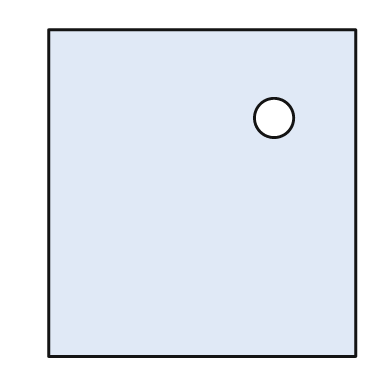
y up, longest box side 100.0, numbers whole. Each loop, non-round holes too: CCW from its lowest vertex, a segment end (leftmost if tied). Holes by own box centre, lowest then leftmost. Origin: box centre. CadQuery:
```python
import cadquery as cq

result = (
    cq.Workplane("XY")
    .moveTo(-47.0, -50.0)
    .lineTo(47.0, -50.0)
    .lineTo(47.0, 50.0)
    .lineTo(-47.0, 50.0)
    .close()
    .moveTo(22.0, 23.0)
    .circle(6.0)
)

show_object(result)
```